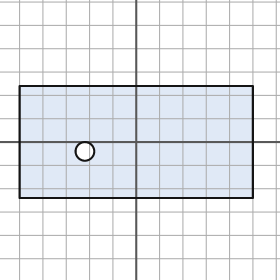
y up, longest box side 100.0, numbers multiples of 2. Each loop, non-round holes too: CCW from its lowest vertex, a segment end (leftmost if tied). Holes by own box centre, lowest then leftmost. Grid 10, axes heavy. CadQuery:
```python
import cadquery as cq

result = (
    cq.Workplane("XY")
    .moveTo(-50.0, -24.0)
    .lineTo(50.0, -24.0)
    .lineTo(50.0, 24.0)
    .lineTo(-50.0, 24.0)
    .close()
    .moveTo(-22.0, -4.0)
    .circle(4.0)
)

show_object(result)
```